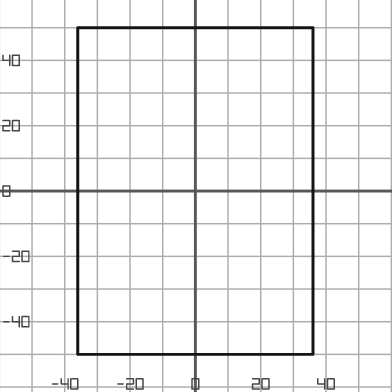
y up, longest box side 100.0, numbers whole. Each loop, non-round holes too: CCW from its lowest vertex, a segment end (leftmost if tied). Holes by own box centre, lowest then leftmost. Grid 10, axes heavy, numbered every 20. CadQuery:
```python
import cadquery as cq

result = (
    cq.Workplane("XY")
    .moveTo(-36.0, -50.0)
    .lineTo(36.0, -50.0)
    .lineTo(36.0, 50.0)
    .lineTo(-36.0, 50.0)
    .close()
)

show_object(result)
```